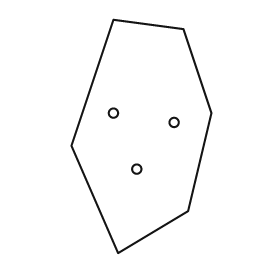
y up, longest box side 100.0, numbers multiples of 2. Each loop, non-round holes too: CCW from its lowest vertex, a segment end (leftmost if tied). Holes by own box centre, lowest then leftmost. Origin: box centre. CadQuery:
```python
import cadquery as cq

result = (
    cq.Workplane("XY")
    .moveTo(-10.0, -50.0)
    .lineTo(20.0, -32.0)
    .lineTo(30.0, 10.0)
    .lineTo(18.0, 46.0)
    .lineTo(-12.0, 50.0)
    .lineTo(-30.0, -4.0)
    .close()
    .moveTo(-2.0, -14.0)
    .circle(2.0)
    .moveTo(14.0, 6.0)
    .circle(2.0)
    .moveTo(-12.0, 10.0)
    .circle(2.0)
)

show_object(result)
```